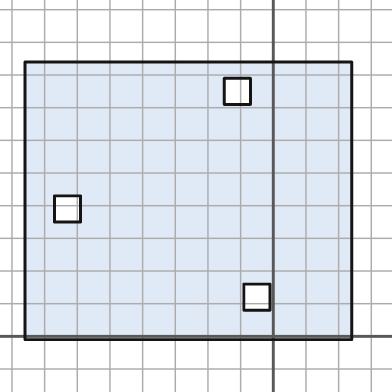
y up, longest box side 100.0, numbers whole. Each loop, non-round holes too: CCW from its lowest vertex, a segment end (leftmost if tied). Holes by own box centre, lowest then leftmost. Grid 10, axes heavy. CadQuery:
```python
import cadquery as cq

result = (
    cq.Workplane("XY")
    .moveTo(-76.0, -1.0)
    .lineTo(24.0, -1.0)
    .lineTo(24.0, 84.0)
    .lineTo(-76.0, 84.0)
    .close()
    .moveTo(-9.0, 8.0)
    .lineTo(-1.0, 8.0)
    .lineTo(-1.0, 16.0)
    .lineTo(-9.0, 16.0)
    .close()
    .moveTo(-67.0, 35.0)
    .lineTo(-59.0, 35.0)
    .lineTo(-59.0, 43.0)
    .lineTo(-67.0, 43.0)
    .close()
    .moveTo(-15.0, 71.0)
    .lineTo(-7.0, 71.0)
    .lineTo(-7.0, 79.0)
    .lineTo(-15.0, 79.0)
    .close()
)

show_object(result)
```